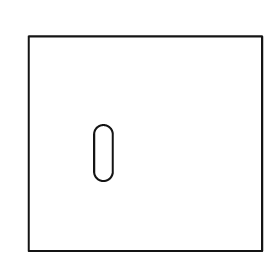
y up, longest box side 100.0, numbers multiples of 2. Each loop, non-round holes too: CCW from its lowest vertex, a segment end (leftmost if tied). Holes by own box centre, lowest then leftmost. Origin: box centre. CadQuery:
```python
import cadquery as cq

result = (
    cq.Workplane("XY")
    .moveTo(-50.0, -46.0)
    .lineTo(50.0, -46.0)
    .lineTo(50.0, 46.0)
    .lineTo(-50.0, 46.0)
    .close()
    .moveTo(-22.0, -12.0)
    .threePointArc((-18.0, -16.0), (-14.0, -12.0))
    .lineTo(-14.0, 4.0)
    .threePointArc((-18.0, 8.0), (-22.0, 4.0))
    .close()
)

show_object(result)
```